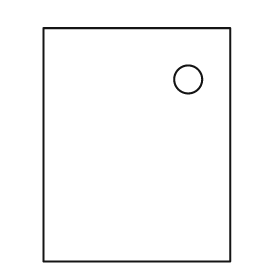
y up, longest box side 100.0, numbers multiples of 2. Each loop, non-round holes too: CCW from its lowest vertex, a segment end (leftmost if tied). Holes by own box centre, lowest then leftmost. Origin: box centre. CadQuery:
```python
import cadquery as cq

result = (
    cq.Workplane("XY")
    .moveTo(-40.0, -50.0)
    .lineTo(40.0, -50.0)
    .lineTo(40.0, 50.0)
    .lineTo(-40.0, 50.0)
    .close()
    .moveTo(22.0, 28.0)
    .circle(6.0)
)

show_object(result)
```